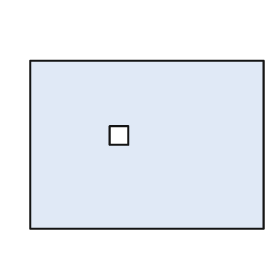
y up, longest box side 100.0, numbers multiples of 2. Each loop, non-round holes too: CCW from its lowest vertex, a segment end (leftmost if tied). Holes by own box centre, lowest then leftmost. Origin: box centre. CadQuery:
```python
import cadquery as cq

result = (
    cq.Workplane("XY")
    .moveTo(-50.0, -36.0)
    .lineTo(50.0, -36.0)
    .lineTo(50.0, 36.0)
    .lineTo(-50.0, 36.0)
    .close()
    .moveTo(-16.0, 0.0)
    .lineTo(-8.0, 0.0)
    .lineTo(-8.0, 8.0)
    .lineTo(-16.0, 8.0)
    .close()
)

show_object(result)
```